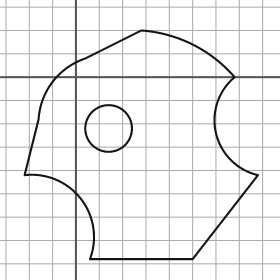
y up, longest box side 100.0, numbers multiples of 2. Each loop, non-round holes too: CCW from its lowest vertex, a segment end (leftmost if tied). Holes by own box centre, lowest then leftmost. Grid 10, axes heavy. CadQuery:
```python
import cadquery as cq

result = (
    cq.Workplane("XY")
    .moveTo(6.0, -78.0)
    .lineTo(50.0, -78.0)
    .lineTo(78.0, -42.0)
    .threePointArc((60.0, -24.0), (68.0, 0.0))
    .threePointArc((50.0, 14.0), (28.0, 20.0))
    .lineTo(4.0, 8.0)
    .threePointArc((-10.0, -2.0), (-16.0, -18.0))
    .lineTo(-22.0, -42.0)
    .threePointArc((2.0, -52.0), (6.0, -78.0))
    .close()
    .moveTo(14.0, -22.0)
    .circle(10.0)
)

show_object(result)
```